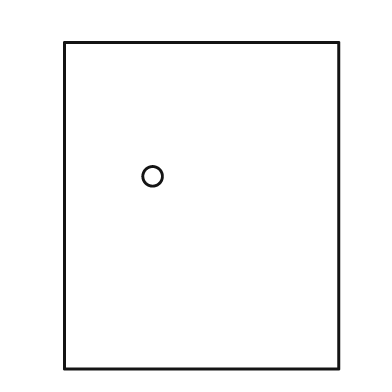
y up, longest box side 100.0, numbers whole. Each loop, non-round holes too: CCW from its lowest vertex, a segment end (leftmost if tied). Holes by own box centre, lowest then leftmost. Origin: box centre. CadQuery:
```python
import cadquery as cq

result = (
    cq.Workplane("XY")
    .moveTo(-42.0, -50.0)
    .lineTo(42.0, -50.0)
    .lineTo(42.0, 50.0)
    .lineTo(-42.0, 50.0)
    .close()
    .moveTo(-15.0, 9.0)
    .circle(3.0)
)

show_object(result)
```